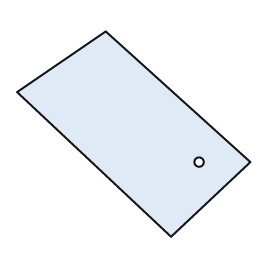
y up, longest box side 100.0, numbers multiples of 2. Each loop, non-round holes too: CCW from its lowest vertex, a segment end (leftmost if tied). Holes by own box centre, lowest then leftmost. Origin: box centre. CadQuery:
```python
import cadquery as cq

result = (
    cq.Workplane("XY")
    .moveTo(16.0, -44.0)
    .lineTo(50.0, -12.0)
    .lineTo(-12.0, 44.0)
    .lineTo(-50.0, 18.0)
    .close()
    .moveTo(28.0, -12.0)
    .circle(2.0)
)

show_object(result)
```